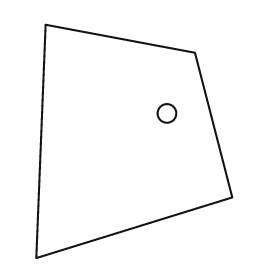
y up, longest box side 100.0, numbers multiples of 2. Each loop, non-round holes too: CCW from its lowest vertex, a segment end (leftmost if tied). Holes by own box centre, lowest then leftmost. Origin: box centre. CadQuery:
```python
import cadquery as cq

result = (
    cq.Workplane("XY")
    .moveTo(-42.0, -50.0)
    .lineTo(42.0, -24.0)
    .lineTo(26.0, 38.0)
    .lineTo(-38.0, 50.0)
    .close()
    .moveTo(14.0, 12.0)
    .circle(4.0)
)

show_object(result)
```